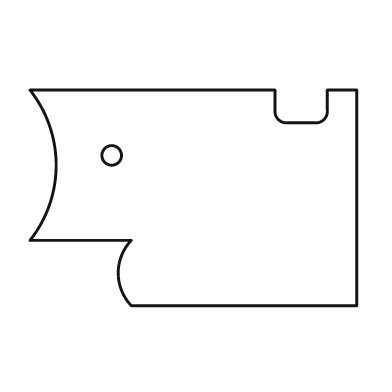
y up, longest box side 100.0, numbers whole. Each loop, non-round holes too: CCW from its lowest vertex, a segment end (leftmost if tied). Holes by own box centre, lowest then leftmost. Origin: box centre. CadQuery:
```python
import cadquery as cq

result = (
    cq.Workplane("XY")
    .moveTo(-19.0, -33.0)
    .lineTo(50.0, -33.0)
    .lineTo(50.0, 33.0)
    .lineTo(41.0, 33.0)
    .lineTo(41.0, 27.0)
    .threePointArc((40.0, 24.0), (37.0, 23.0))
    .lineTo(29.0, 23.0)
    .threePointArc((26.0, 24.0), (25.0, 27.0))
    .lineTo(25.0, 33.0)
    .lineTo(-50.0, 33.0)
    .threePointArc((-42.0, 10.0), (-50.0, -13.0))
    .lineTo(-19.0, -13.0)
    .threePointArc((-23.0, -23.0), (-19.0, -33.0))
    .close()
    .moveTo(-25.0, 13.0)
    .circle(3.0)
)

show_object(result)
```